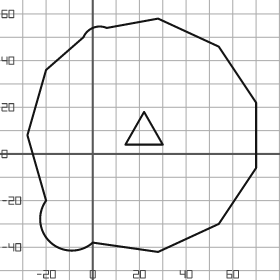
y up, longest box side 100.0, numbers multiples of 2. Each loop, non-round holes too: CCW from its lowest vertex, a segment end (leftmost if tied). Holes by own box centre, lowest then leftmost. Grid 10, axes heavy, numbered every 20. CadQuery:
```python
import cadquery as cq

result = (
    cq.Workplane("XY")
    .moveTo(28.0, -42.0)
    .lineTo(54.0, -30.0)
    .lineTo(70.0, -6.0)
    .lineTo(70.0, 22.0)
    .lineTo(54.0, 46.0)
    .lineTo(28.0, 58.0)
    .lineTo(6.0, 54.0)
    .threePointArc((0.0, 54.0), (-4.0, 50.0))
    .lineTo(-20.0, 36.0)
    .lineTo(-28.0, 8.0)
    .lineTo(-20.0, -20.0)
    .threePointArc((-18.0, -38.0), (0.0, -38.0))
    .close()
    .moveTo(14.0, 4.0)
    .lineTo(30.0, 4.0)
    .lineTo(22.0, 18.0)
    .close()
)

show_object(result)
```